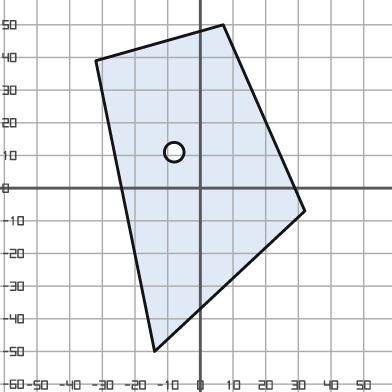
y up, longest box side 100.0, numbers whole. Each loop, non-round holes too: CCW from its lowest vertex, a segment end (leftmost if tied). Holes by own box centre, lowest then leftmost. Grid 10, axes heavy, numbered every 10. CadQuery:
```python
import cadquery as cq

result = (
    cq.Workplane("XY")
    .moveTo(-14.0, -50.0)
    .lineTo(32.0, -7.0)
    .lineTo(7.0, 50.0)
    .lineTo(-32.0, 39.0)
    .close()
    .moveTo(-8.0, 11.0)
    .circle(3.0)
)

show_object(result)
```